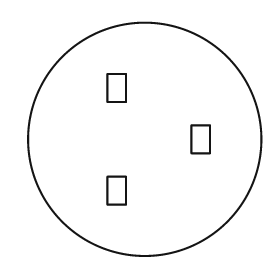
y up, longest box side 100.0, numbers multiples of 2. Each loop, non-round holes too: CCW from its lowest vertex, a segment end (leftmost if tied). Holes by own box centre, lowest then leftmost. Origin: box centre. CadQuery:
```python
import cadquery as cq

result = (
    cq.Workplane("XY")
    .moveTo(0.0, 0.0)
    .circle(50.0)
    .moveTo(-16.0, -28.0)
    .lineTo(-8.0, -28.0)
    .lineTo(-8.0, -16.0)
    .lineTo(-16.0, -16.0)
    .close()
    .moveTo(20.0, -6.0)
    .lineTo(28.0, -6.0)
    .lineTo(28.0, 6.0)
    .lineTo(20.0, 6.0)
    .close()
    .moveTo(-16.0, 16.0)
    .lineTo(-8.0, 16.0)
    .lineTo(-8.0, 28.0)
    .lineTo(-16.0, 28.0)
    .close()
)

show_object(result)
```